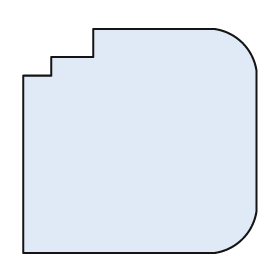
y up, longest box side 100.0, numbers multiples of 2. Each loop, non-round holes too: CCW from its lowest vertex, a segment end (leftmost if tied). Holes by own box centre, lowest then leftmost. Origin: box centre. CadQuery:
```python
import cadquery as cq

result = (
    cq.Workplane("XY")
    .moveTo(-50.0, -48.0)
    .lineTo(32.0, -48.0)
    .threePointArc((44.0, -42.0), (50.0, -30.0))
    .lineTo(50.0, 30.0)
    .threePointArc((44.0, 42.0), (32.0, 48.0))
    .lineTo(-20.0, 48.0)
    .lineTo(-20.0, 36.0)
    .lineTo(-38.0, 36.0)
    .lineTo(-38.0, 28.0)
    .lineTo(-50.0, 28.0)
    .close()
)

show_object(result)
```